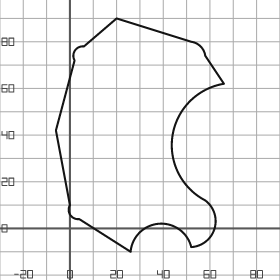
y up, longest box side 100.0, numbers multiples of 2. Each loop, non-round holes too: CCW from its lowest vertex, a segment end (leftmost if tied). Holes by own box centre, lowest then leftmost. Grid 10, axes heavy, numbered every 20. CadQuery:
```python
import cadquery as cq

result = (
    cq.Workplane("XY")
    .moveTo(26.0, -10.0)
    .threePointArc((38.0, 2.0), (52.0, -8.0))
    .threePointArc((62.0, 0.0), (58.0, 12.0))
    .threePointArc((44.0, 40.0), (66.0, 62.0))
    .lineTo(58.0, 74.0)
    .threePointArc((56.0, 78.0), (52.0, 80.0))
    .lineTo(20.0, 90.0)
    .lineTo(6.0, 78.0)
    .threePointArc((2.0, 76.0), (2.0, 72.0))
    .lineTo(-6.0, 42.0)
    .lineTo(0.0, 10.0)
    .threePointArc((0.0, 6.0), (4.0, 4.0))
    .close()
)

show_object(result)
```